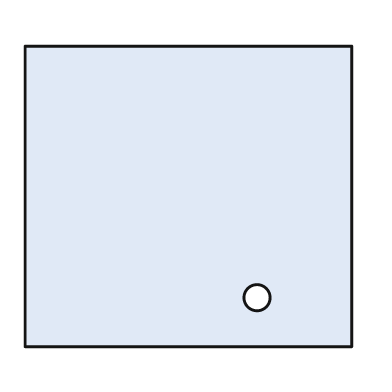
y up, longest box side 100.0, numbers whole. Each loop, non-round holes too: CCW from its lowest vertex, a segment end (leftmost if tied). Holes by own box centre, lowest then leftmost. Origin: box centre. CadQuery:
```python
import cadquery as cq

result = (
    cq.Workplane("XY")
    .moveTo(-50.0, -46.0)
    .lineTo(50.0, -46.0)
    .lineTo(50.0, 46.0)
    .lineTo(-50.0, 46.0)
    .close()
    .moveTo(21.0, -31.0)
    .circle(4.0)
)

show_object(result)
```